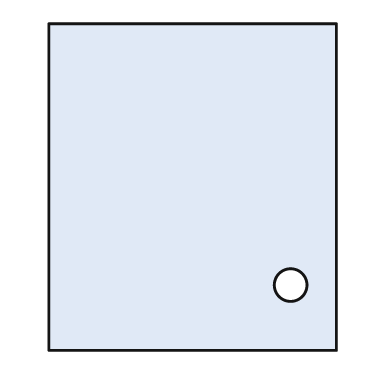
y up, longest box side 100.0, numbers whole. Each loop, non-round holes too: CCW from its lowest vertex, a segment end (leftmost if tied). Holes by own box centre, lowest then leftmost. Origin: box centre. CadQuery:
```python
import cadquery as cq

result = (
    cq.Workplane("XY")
    .moveTo(-44.0, -50.0)
    .lineTo(44.0, -50.0)
    .lineTo(44.0, 50.0)
    .lineTo(-44.0, 50.0)
    .close()
    .moveTo(30.0, -30.0)
    .circle(5.0)
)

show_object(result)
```